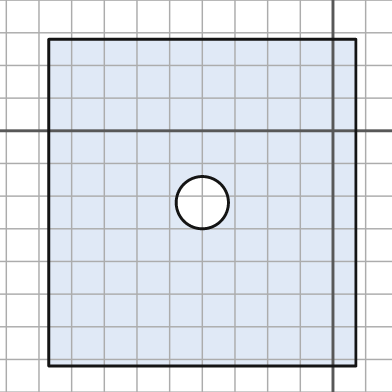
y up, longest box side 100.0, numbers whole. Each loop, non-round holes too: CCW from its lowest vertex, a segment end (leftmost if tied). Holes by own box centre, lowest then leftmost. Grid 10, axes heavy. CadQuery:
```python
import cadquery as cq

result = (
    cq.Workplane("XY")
    .moveTo(-87.0, -72.0)
    .lineTo(7.0, -72.0)
    .lineTo(7.0, 28.0)
    .lineTo(-87.0, 28.0)
    .close()
    .moveTo(-40.0, -22.0)
    .circle(8.0)
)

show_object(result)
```